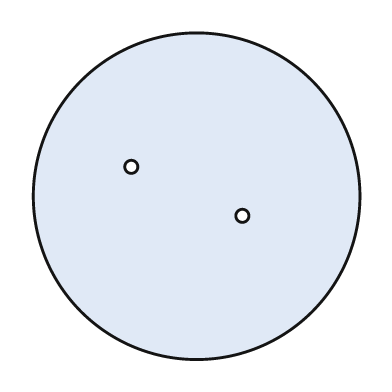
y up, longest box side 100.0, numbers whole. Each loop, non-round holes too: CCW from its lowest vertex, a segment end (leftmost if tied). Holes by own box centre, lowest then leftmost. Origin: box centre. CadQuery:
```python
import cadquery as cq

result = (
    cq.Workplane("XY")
    .moveTo(0.0, 0.0)
    .circle(50.0)
    .moveTo(14.0, -6.0)
    .circle(2.0)
    .moveTo(-20.0, 9.0)
    .circle(2.0)
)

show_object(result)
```